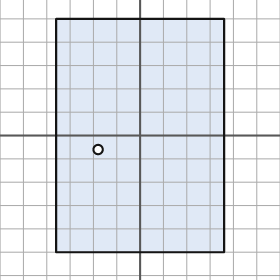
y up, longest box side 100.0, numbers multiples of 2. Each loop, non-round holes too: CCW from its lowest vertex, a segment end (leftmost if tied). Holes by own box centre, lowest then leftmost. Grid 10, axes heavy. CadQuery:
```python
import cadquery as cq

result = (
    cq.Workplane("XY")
    .moveTo(-36.0, -50.0)
    .lineTo(36.0, -50.0)
    .lineTo(36.0, 50.0)
    .lineTo(-36.0, 50.0)
    .close()
    .moveTo(-18.0, -6.0)
    .circle(2.0)
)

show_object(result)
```